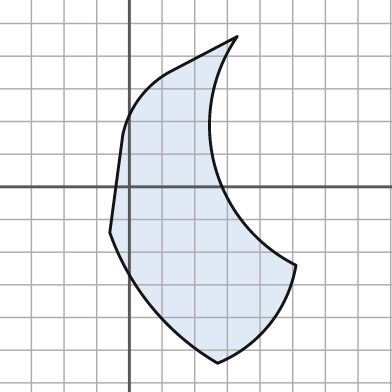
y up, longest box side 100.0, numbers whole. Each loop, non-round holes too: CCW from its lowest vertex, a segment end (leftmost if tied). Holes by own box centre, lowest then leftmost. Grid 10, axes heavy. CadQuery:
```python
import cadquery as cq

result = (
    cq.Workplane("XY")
    .moveTo(27.0, -54.0)
    .threePointArc((43.0, -42.0), (51.0, -24.0))
    .threePointArc((26.0, 7.0), (33.0, 46.0))
    .lineTo(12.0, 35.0)
    .threePointArc((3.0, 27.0), (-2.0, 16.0))
    .lineTo(-6.0, -14.0)
    .threePointArc((7.0, -37.0), (27.0, -54.0))
    .close()
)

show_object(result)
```